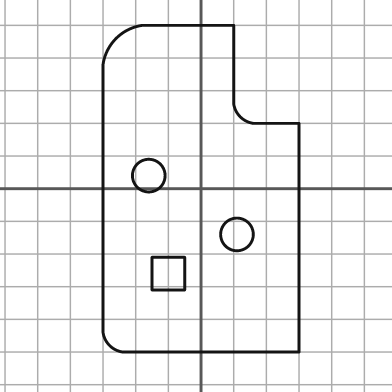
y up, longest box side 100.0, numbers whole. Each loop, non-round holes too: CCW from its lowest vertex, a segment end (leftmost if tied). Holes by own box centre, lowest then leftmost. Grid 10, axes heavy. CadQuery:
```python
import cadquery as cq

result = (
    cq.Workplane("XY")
    .moveTo(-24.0, -50.0)
    .lineTo(30.0, -50.0)
    .lineTo(30.0, 20.0)
    .lineTo(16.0, 20.0)
    .threePointArc((12.0, 22.0), (10.0, 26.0))
    .lineTo(10.0, 50.0)
    .lineTo(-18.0, 50.0)
    .threePointArc((-26.0, 46.0), (-30.0, 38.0))
    .lineTo(-30.0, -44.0)
    .threePointArc((-28.0, -48.0), (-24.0, -50.0))
    .close()
    .moveTo(-15.0, -31.0)
    .lineTo(-5.0, -31.0)
    .lineTo(-5.0, -21.0)
    .lineTo(-15.0, -21.0)
    .close()
    .moveTo(11.0, -14.0)
    .circle(5.0)
    .moveTo(-16.0, 4.0)
    .circle(5.0)
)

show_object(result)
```